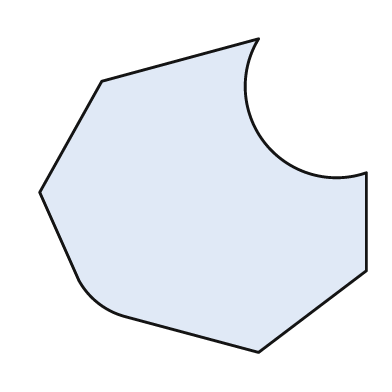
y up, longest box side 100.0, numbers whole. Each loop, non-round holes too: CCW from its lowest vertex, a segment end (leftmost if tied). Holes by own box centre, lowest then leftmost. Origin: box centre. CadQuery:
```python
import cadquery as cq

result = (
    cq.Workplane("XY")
    .moveTo(17.0, -48.0)
    .lineTo(50.0, -23.0)
    .lineTo(50.0, 7.0)
    .threePointArc((19.0, 16.0), (17.0, 48.0))
    .lineTo(-31.0, 35.0)
    .lineTo(-50.0, 1.0)
    .lineTo(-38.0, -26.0)
    .threePointArc((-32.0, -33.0), (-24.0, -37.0))
    .close()
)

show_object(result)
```